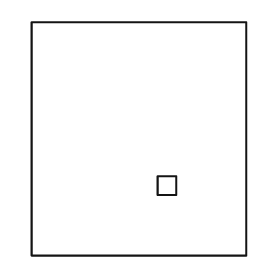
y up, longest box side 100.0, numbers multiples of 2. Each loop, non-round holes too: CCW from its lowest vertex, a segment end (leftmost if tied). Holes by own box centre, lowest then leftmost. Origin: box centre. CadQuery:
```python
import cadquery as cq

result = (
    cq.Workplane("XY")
    .moveTo(-46.0, -50.0)
    .lineTo(46.0, -50.0)
    .lineTo(46.0, 50.0)
    .lineTo(-46.0, 50.0)
    .close()
    .moveTo(8.0, -24.0)
    .lineTo(16.0, -24.0)
    .lineTo(16.0, -16.0)
    .lineTo(8.0, -16.0)
    .close()
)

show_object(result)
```